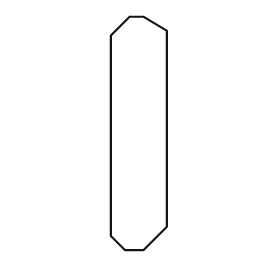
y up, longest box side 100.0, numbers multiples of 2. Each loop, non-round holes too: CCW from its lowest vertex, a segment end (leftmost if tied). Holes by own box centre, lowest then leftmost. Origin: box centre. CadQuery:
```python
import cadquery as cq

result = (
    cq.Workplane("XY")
    .moveTo(-6.0, -50.0)
    .lineTo(2.0, -50.0)
    .lineTo(12.0, -40.0)
    .lineTo(12.0, 44.0)
    .lineTo(2.0, 50.0)
    .lineTo(-4.0, 50.0)
    .lineTo(-12.0, 42.0)
    .lineTo(-12.0, -44.0)
    .close()
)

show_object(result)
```